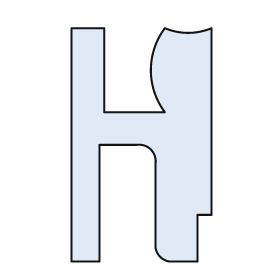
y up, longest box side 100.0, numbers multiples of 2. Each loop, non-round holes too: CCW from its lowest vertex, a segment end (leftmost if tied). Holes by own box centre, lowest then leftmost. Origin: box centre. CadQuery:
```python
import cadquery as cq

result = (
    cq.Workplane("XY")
    .moveTo(-30.0, -50.0)
    .lineTo(-18.0, -50.0)
    .lineTo(-18.0, 0.0)
    .lineTo(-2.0, 0.0)
    .threePointArc((4.0, -2.0), (6.0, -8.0))
    .lineTo(6.0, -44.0)
    .threePointArc((8.0, -48.0), (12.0, -50.0))
    .lineTo(24.0, -50.0)
    .lineTo(24.0, -30.0)
    .lineTo(30.0, -30.0)
    .lineTo(30.0, 50.0)
    .threePointArc((20.0, 48.0), (10.0, 50.0))
    .threePointArc((4.0, 32.0), (10.0, 14.0))
    .lineTo(-16.0, 14.0)
    .lineTo(-16.0, 50.0)
    .lineTo(-30.0, 50.0)
    .close()
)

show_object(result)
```